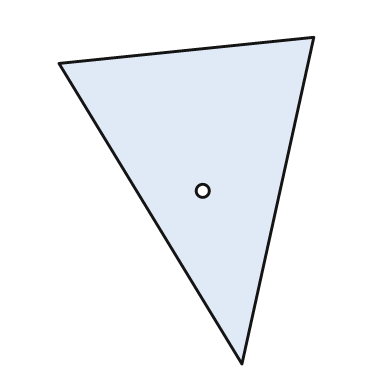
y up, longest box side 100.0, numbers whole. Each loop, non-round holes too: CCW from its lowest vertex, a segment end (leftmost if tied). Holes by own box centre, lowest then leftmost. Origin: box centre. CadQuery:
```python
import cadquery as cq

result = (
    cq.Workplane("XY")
    .moveTo(17.0, -50.0)
    .lineTo(39.0, 50.0)
    .lineTo(-39.0, 42.0)
    .close()
    .moveTo(5.0, 3.0)
    .circle(2.0)
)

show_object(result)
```